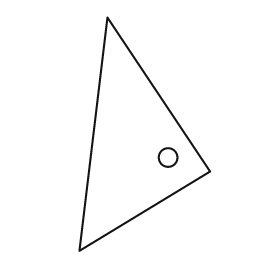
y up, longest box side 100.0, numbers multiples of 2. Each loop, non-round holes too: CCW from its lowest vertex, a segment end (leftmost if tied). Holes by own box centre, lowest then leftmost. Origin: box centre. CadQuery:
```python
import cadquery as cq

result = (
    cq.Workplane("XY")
    .moveTo(-28.0, -50.0)
    .lineTo(28.0, -16.0)
    .lineTo(-16.0, 50.0)
    .close()
    .moveTo(10.0, -10.0)
    .circle(4.0)
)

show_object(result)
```